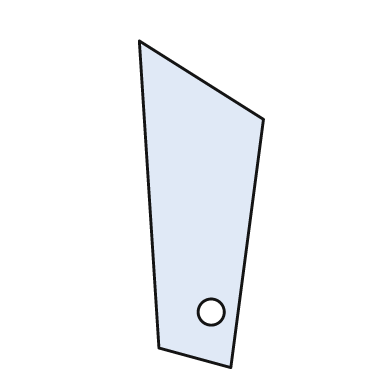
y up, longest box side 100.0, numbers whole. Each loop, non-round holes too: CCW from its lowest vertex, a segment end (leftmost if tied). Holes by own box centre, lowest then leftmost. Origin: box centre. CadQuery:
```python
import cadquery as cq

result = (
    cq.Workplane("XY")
    .moveTo(9.0, -50.0)
    .lineTo(19.0, 26.0)
    .lineTo(-19.0, 50.0)
    .lineTo(-13.0, -44.0)
    .close()
    .moveTo(3.0, -33.0)
    .circle(4.0)
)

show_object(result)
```